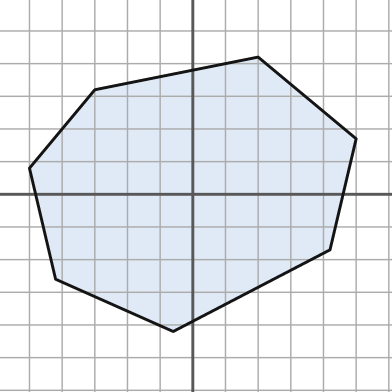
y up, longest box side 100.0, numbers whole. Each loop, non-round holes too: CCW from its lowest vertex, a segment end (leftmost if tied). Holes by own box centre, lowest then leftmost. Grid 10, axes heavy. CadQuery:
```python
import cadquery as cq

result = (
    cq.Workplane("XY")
    .moveTo(-6.0, -42.0)
    .lineTo(42.0, -17.0)
    .lineTo(50.0, 17.0)
    .lineTo(20.0, 42.0)
    .lineTo(-30.0, 32.0)
    .lineTo(-50.0, 8.0)
    .lineTo(-42.0, -26.0)
    .close()
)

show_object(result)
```